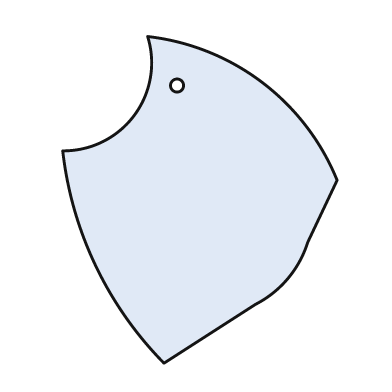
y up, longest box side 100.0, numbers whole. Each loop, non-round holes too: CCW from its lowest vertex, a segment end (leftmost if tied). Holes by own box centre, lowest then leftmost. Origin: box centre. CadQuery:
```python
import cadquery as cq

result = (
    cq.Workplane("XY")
    .moveTo(-11.0, -50.0)
    .lineTo(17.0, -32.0)
    .threePointArc((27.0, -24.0), (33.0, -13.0))
    .lineTo(42.0, 6.0)
    .threePointArc((19.0, 36.0), (-16.0, 50.0))
    .threePointArc((-20.0, 26.0), (-42.0, 15.0))
    .threePointArc((-32.0, -20.0), (-11.0, -50.0))
    .close()
    .moveTo(-7.0, 35.0)
    .circle(2.0)
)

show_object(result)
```